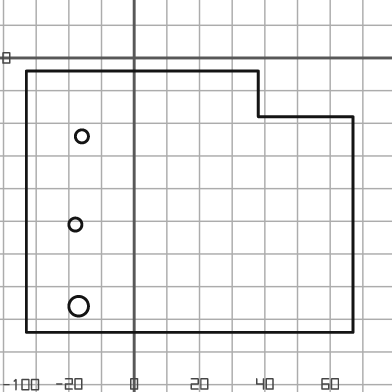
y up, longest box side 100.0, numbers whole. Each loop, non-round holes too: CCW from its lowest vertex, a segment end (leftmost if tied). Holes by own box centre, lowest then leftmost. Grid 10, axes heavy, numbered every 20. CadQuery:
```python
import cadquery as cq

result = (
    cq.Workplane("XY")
    .moveTo(-33.0, -84.0)
    .lineTo(67.0, -84.0)
    .lineTo(67.0, -18.0)
    .lineTo(38.0, -18.0)
    .lineTo(38.0, -4.0)
    .lineTo(-33.0, -4.0)
    .close()
    .moveTo(-17.0, -76.0)
    .circle(3.0)
    .moveTo(-18.0, -51.0)
    .circle(2.0)
    .moveTo(-16.0, -24.0)
    .circle(2.0)
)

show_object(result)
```